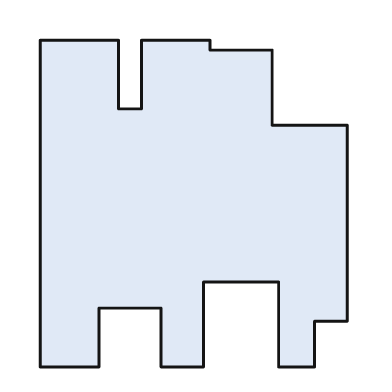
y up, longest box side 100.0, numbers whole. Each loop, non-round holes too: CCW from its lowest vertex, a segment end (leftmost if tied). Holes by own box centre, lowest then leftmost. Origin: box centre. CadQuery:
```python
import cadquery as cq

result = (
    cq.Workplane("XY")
    .moveTo(-47.0, -50.0)
    .lineTo(-29.0, -50.0)
    .lineTo(-29.0, -32.0)
    .lineTo(-10.0, -32.0)
    .lineTo(-10.0, -50.0)
    .lineTo(3.0, -50.0)
    .lineTo(3.0, -24.0)
    .lineTo(26.0, -24.0)
    .lineTo(26.0, -50.0)
    .lineTo(37.0, -50.0)
    .lineTo(37.0, -36.0)
    .lineTo(47.0, -36.0)
    .lineTo(47.0, 24.0)
    .lineTo(24.0, 24.0)
    .lineTo(24.0, 47.0)
    .lineTo(5.0, 47.0)
    .lineTo(5.0, 50.0)
    .lineTo(-16.0, 50.0)
    .lineTo(-16.0, 29.0)
    .lineTo(-23.0, 29.0)
    .lineTo(-23.0, 50.0)
    .lineTo(-47.0, 50.0)
    .close()
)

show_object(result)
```